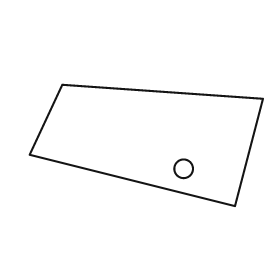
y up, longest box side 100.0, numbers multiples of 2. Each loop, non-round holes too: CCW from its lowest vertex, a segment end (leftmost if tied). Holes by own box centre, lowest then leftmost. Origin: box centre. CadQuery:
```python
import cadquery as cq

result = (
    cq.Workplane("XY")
    .moveTo(38.0, -26.0)
    .lineTo(50.0, 20.0)
    .lineTo(-36.0, 26.0)
    .lineTo(-50.0, -4.0)
    .close()
    .moveTo(16.0, -10.0)
    .circle(4.0)
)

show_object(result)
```